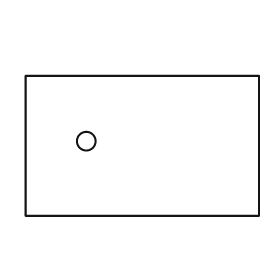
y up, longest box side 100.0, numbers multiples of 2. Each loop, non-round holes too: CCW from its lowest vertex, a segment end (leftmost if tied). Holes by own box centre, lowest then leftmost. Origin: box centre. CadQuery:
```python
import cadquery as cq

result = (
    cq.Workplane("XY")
    .moveTo(-50.0, -30.0)
    .lineTo(50.0, -30.0)
    .lineTo(50.0, 30.0)
    .lineTo(-50.0, 30.0)
    .close()
    .moveTo(-24.0, 2.0)
    .circle(4.0)
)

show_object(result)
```